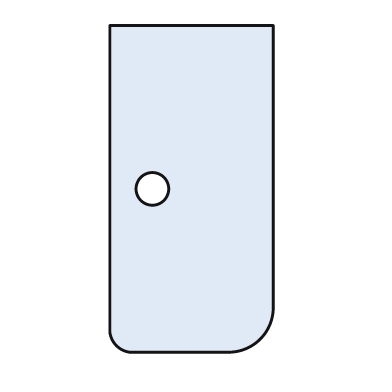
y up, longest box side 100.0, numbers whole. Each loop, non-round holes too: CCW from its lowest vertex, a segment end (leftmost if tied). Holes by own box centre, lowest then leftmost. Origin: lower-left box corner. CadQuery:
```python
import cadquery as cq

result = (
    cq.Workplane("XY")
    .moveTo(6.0, 0.0)
    .lineTo(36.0, 0.0)
    .threePointArc((46.0, 4.0), (50.0, 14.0))
    .lineTo(50.0, 100.0)
    .lineTo(0.0, 100.0)
    .lineTo(0.0, 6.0)
    .threePointArc((2.0, 2.0), (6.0, 0.0))
    .close()
    .moveTo(13.0, 50.0)
    .circle(5.0)
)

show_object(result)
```